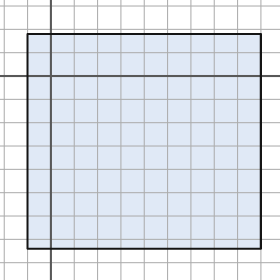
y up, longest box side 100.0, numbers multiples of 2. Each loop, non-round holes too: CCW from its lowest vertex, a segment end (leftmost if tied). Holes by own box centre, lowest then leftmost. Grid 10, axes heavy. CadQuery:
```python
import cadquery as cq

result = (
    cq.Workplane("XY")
    .moveTo(-10.0, -74.0)
    .lineTo(90.0, -74.0)
    .lineTo(90.0, 18.0)
    .lineTo(-10.0, 18.0)
    .close()
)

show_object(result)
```